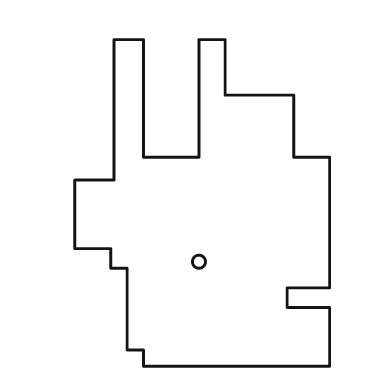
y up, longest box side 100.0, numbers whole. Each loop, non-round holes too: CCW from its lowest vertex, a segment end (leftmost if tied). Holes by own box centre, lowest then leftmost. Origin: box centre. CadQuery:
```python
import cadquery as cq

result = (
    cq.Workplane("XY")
    .moveTo(-18.0, -50.0)
    .lineTo(39.0, -50.0)
    .lineTo(39.0, -32.0)
    .lineTo(26.0, -32.0)
    .lineTo(26.0, -26.0)
    .lineTo(39.0, -26.0)
    .lineTo(39.0, 14.0)
    .lineTo(28.0, 14.0)
    .lineTo(28.0, 33.0)
    .lineTo(7.0, 33.0)
    .lineTo(7.0, 50.0)
    .lineTo(-1.0, 50.0)
    .lineTo(-1.0, 14.0)
    .lineTo(-18.0, 14.0)
    .lineTo(-18.0, 50.0)
    .lineTo(-27.0, 50.0)
    .lineTo(-27.0, 7.0)
    .lineTo(-39.0, 7.0)
    .lineTo(-39.0, -14.0)
    .lineTo(-28.0, -14.0)
    .lineTo(-28.0, -20.0)
    .lineTo(-23.0, -20.0)
    .lineTo(-23.0, -45.0)
    .lineTo(-18.0, -45.0)
    .close()
    .moveTo(-1.0, -18.0)
    .circle(2.0)
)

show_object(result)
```